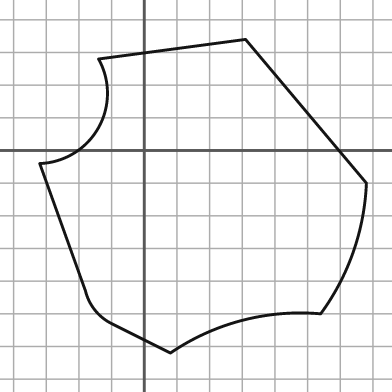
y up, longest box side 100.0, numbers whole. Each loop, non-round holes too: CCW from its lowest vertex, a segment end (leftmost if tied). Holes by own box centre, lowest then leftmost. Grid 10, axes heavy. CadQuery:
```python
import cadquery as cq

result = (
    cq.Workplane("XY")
    .moveTo(8.0, -62.0)
    .threePointArc((30.0, -52.0), (54.0, -50.0))
    .threePointArc((64.0, -31.0), (68.0, -10.0))
    .lineTo(31.0, 34.0)
    .lineTo(-14.0, 28.0)
    .threePointArc((-14.0, 7.0), (-32.0, -4.0))
    .lineTo(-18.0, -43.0)
    .threePointArc((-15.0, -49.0), (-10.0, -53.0))
    .close()
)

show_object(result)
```